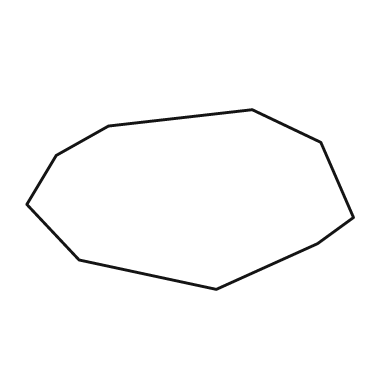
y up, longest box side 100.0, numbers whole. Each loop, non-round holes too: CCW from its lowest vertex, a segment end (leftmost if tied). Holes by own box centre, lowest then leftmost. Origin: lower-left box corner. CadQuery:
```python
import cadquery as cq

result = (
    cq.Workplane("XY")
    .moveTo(58.0, 0.0)
    .lineTo(89.0, 14.0)
    .lineTo(100.0, 22.0)
    .lineTo(90.0, 45.0)
    .lineTo(69.0, 55.0)
    .lineTo(25.0, 50.0)
    .lineTo(9.0, 41.0)
    .lineTo(0.0, 26.0)
    .lineTo(16.0, 9.0)
    .close()
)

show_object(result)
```